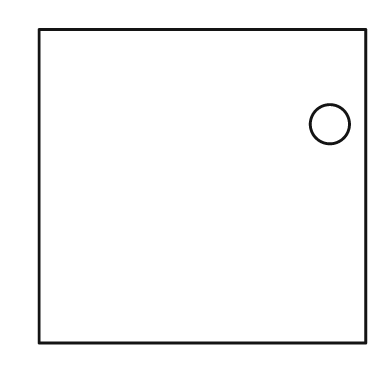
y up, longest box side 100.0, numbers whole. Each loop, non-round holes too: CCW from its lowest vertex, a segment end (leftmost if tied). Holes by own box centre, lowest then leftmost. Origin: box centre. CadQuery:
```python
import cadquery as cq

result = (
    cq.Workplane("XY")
    .moveTo(-50.0, -48.0)
    .lineTo(50.0, -48.0)
    .lineTo(50.0, 48.0)
    .lineTo(-50.0, 48.0)
    .close()
    .moveTo(39.0, 19.0)
    .circle(6.0)
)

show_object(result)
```